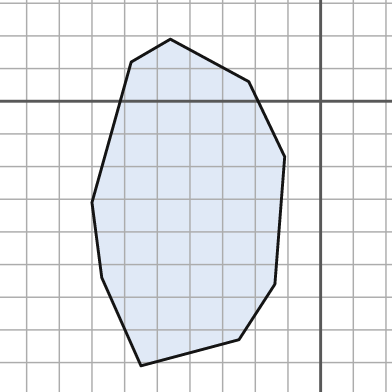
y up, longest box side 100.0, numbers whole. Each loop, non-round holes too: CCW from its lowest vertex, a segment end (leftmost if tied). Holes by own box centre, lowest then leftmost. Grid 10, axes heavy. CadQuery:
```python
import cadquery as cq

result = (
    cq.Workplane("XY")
    .moveTo(-55.0, -81.0)
    .lineTo(-25.0, -73.0)
    .lineTo(-14.0, -56.0)
    .lineTo(-11.0, -17.0)
    .lineTo(-22.0, 6.0)
    .lineTo(-46.0, 19.0)
    .lineTo(-58.0, 12.0)
    .lineTo(-70.0, -31.0)
    .lineTo(-67.0, -54.0)
    .close()
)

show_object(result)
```